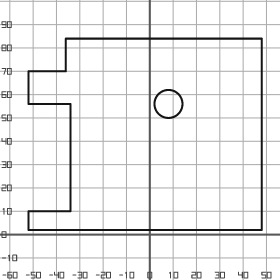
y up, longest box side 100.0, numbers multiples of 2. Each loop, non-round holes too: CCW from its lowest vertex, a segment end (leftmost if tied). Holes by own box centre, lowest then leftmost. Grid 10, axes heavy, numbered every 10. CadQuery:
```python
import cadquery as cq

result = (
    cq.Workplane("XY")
    .moveTo(-52.0, 2.0)
    .lineTo(48.0, 2.0)
    .lineTo(48.0, 84.0)
    .lineTo(-36.0, 84.0)
    .lineTo(-36.0, 70.0)
    .lineTo(-52.0, 70.0)
    .lineTo(-52.0, 56.0)
    .lineTo(-34.0, 56.0)
    .lineTo(-34.0, 10.0)
    .lineTo(-52.0, 10.0)
    .close()
    .moveTo(8.0, 56.0)
    .circle(6.0)
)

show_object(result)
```